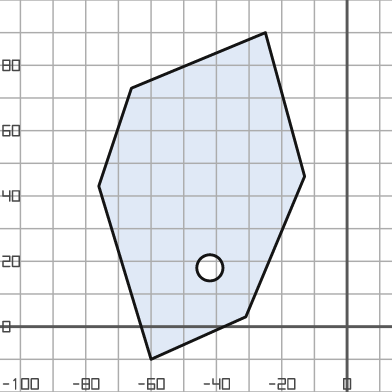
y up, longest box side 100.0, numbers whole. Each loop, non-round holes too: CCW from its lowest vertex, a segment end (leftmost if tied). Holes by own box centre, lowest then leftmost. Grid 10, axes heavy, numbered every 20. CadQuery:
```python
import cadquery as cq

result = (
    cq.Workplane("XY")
    .moveTo(-60.0, -10.0)
    .lineTo(-31.0, 3.0)
    .lineTo(-13.0, 46.0)
    .lineTo(-25.0, 90.0)
    .lineTo(-66.0, 73.0)
    .lineTo(-76.0, 43.0)
    .close()
    .moveTo(-42.0, 18.0)
    .circle(4.0)
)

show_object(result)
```